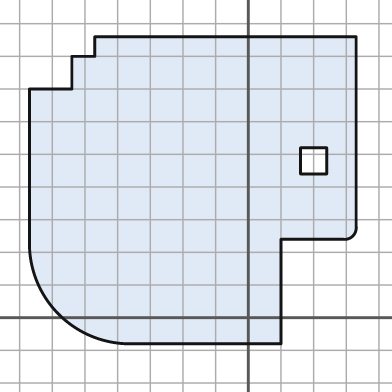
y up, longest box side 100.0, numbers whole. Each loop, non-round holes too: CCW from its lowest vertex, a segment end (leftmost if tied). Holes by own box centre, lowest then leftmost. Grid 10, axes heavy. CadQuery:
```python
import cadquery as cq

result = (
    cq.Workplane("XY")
    .moveTo(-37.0, -8.0)
    .lineTo(10.0, -8.0)
    .lineTo(10.0, 24.0)
    .lineTo(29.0, 24.0)
    .threePointArc((32.0, 25.0), (33.0, 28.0))
    .lineTo(33.0, 86.0)
    .lineTo(-47.0, 86.0)
    .lineTo(-47.0, 80.0)
    .lineTo(-54.0, 80.0)
    .lineTo(-54.0, 70.0)
    .lineTo(-67.0, 70.0)
    .lineTo(-67.0, 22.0)
    .threePointArc((-58.0, 1.0), (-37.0, -8.0))
    .close()
    .moveTo(16.0, 44.0)
    .lineTo(24.0, 44.0)
    .lineTo(24.0, 52.0)
    .lineTo(16.0, 52.0)
    .close()
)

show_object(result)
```